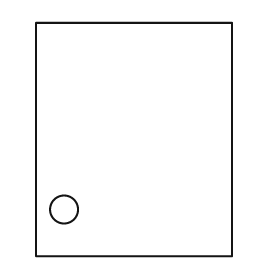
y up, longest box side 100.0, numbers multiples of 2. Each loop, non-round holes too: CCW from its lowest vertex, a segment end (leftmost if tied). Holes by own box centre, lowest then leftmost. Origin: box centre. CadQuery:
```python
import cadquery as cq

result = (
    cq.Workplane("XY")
    .moveTo(-42.0, -50.0)
    .lineTo(42.0, -50.0)
    .lineTo(42.0, 50.0)
    .lineTo(-42.0, 50.0)
    .close()
    .moveTo(-30.0, -30.0)
    .circle(6.0)
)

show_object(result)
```